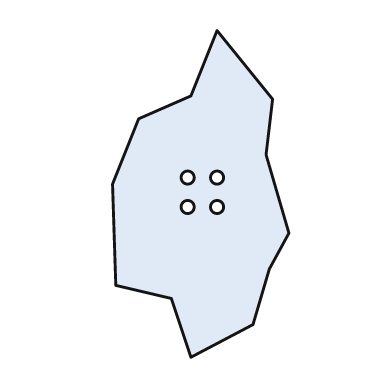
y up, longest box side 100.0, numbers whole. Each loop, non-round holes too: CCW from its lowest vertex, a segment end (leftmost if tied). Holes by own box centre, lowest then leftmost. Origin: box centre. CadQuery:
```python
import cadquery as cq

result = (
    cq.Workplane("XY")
    .moveTo(-3.0, -50.0)
    .lineTo(16.0, -40.0)
    .lineTo(21.0, -23.0)
    .lineTo(27.0, -12.0)
    .lineTo(20.0, 12.0)
    .lineTo(22.0, 29.0)
    .lineTo(5.0, 50.0)
    .lineTo(-3.0, 30.0)
    .lineTo(-19.0, 23.0)
    .lineTo(-27.0, 3.0)
    .lineTo(-26.0, -28.0)
    .lineTo(-9.0, -32.0)
    .close()
    .moveTo(-4.0, -4.0)
    .circle(2.0)
    .moveTo(5.0, -4.0)
    .circle(2.0)
    .moveTo(-4.0, 5.0)
    .circle(2.0)
    .moveTo(5.0, 5.0)
    .circle(2.0)
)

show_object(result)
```